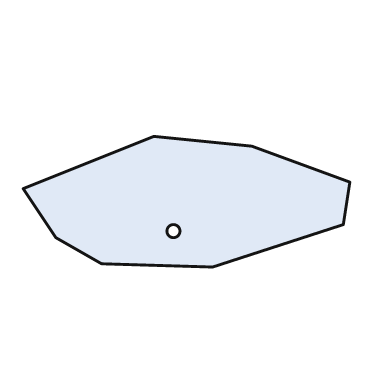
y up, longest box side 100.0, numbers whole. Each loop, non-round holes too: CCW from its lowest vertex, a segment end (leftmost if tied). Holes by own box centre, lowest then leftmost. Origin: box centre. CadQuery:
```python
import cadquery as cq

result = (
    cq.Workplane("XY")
    .moveTo(8.0, -20.0)
    .lineTo(48.0, -7.0)
    .lineTo(50.0, 6.0)
    .lineTo(20.0, 17.0)
    .lineTo(-10.0, 20.0)
    .lineTo(-50.0, 4.0)
    .lineTo(-40.0, -11.0)
    .lineTo(-26.0, -19.0)
    .close()
    .moveTo(-4.0, -9.0)
    .circle(2.0)
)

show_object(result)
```